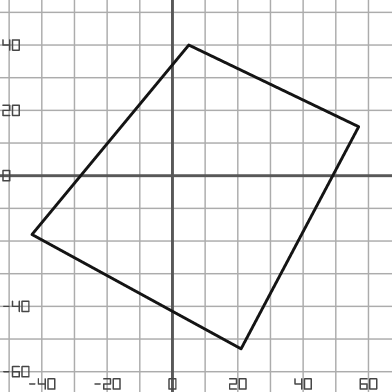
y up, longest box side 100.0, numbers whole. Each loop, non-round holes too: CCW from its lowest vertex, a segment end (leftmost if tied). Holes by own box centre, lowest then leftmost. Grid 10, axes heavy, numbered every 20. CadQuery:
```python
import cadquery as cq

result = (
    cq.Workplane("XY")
    .moveTo(21.0, -53.0)
    .lineTo(57.0, 15.0)
    .lineTo(5.0, 40.0)
    .lineTo(-43.0, -18.0)
    .close()
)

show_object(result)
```